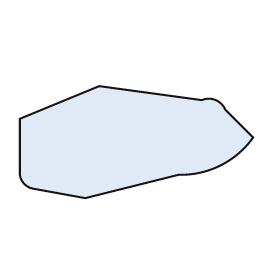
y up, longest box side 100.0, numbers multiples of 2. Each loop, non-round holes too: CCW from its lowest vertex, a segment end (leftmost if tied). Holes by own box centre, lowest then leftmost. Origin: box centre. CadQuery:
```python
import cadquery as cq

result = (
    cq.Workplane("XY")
    .moveTo(-22.0, -24.0)
    .lineTo(18.0, -14.0)
    .threePointArc((36.0, -10.0), (50.0, 2.0))
    .lineTo(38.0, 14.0)
    .threePointArc((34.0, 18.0), (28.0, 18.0))
    .lineTo(-16.0, 24.0)
    .lineTo(-50.0, 10.0)
    .lineTo(-50.0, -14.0)
    .threePointArc((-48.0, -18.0), (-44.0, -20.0))
    .close()
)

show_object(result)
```